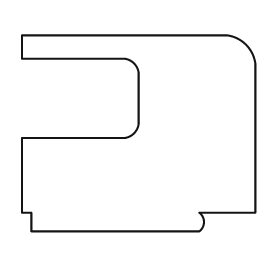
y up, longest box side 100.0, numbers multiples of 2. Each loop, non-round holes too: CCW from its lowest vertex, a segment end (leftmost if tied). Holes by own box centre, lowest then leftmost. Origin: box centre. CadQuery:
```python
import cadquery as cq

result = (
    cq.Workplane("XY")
    .moveTo(-46.0, -42.0)
    .lineTo(26.0, -42.0)
    .threePointArc((28.0, -38.0), (26.0, -34.0))
    .lineTo(50.0, -34.0)
    .lineTo(50.0, 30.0)
    .threePointArc((46.0, 38.0), (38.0, 42.0))
    .lineTo(-50.0, 42.0)
    .lineTo(-50.0, 32.0)
    .lineTo(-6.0, 32.0)
    .threePointArc((-2.0, 30.0), (0.0, 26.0))
    .lineTo(0.0, 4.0)
    .threePointArc((-2.0, 0.0), (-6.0, -2.0))
    .lineTo(-50.0, -2.0)
    .lineTo(-50.0, -34.0)
    .lineTo(-46.0, -34.0)
    .close()
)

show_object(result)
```